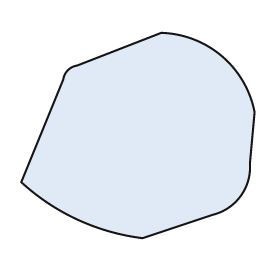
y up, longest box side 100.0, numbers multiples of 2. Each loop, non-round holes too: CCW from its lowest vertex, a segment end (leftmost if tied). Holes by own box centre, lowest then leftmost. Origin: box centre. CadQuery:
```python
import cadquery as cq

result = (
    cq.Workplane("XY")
    .moveTo(2.0, -44.0)
    .lineTo(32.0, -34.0)
    .threePointArc((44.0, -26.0), (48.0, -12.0))
    .lineTo(50.0, 10.0)
    .threePointArc((36.0, 34.0), (10.0, 44.0))
    .lineTo(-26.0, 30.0)
    .threePointArc((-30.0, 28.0), (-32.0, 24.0))
    .lineTo(-50.0, -20.0)
    .threePointArc((-26.0, -36.0), (2.0, -44.0))
    .close()
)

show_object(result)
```